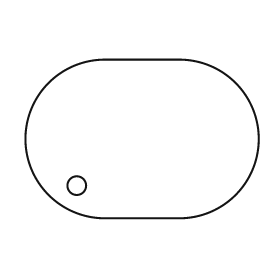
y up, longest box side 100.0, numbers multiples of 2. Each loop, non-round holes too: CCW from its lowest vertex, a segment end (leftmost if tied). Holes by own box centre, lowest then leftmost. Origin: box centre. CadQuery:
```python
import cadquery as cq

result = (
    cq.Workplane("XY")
    .moveTo(-16.0, -34.0)
    .lineTo(16.0, -34.0)
    .threePointArc((50.0, 0.0), (16.0, 34.0))
    .lineTo(-16.0, 34.0)
    .threePointArc((-50.0, 0.0), (-16.0, -34.0))
    .close()
    .moveTo(-28.0, -20.0)
    .circle(4.0)
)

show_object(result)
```